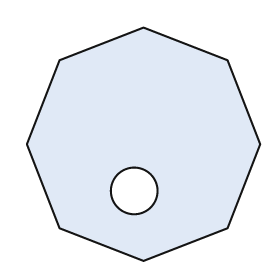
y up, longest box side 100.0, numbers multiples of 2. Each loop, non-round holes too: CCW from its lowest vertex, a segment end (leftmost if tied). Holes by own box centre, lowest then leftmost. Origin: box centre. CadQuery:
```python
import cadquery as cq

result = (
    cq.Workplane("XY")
    .moveTo(0.0, -50.0)
    .lineTo(36.0, -36.0)
    .lineTo(50.0, 0.0)
    .lineTo(36.0, 36.0)
    .lineTo(0.0, 50.0)
    .lineTo(-36.0, 36.0)
    .lineTo(-50.0, 0.0)
    .lineTo(-36.0, -36.0)
    .close()
    .moveTo(-4.0, -20.0)
    .circle(10.0)
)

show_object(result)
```